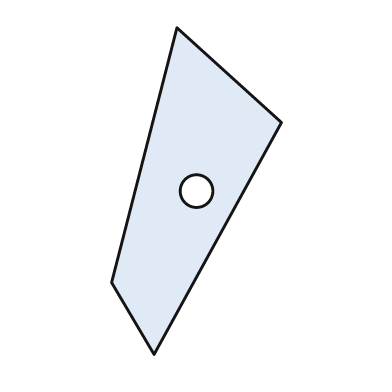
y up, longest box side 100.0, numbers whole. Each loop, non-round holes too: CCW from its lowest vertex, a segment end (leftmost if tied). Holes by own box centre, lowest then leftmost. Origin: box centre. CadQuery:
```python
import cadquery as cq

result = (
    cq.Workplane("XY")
    .moveTo(-13.0, -50.0)
    .lineTo(26.0, 21.0)
    .lineTo(-6.0, 50.0)
    .lineTo(-26.0, -28.0)
    .close()
    .moveTo(0.0, 0.0)
    .circle(5.0)
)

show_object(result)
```